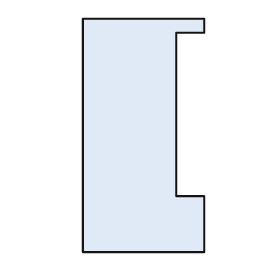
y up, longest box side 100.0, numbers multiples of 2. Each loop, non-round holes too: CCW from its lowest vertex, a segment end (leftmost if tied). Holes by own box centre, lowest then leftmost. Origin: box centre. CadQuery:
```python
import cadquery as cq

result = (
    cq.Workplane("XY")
    .moveTo(-26.0, -50.0)
    .lineTo(26.0, -50.0)
    .lineTo(26.0, -26.0)
    .lineTo(14.0, -26.0)
    .lineTo(14.0, 44.0)
    .lineTo(26.0, 44.0)
    .lineTo(26.0, 50.0)
    .lineTo(-26.0, 50.0)
    .close()
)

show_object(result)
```